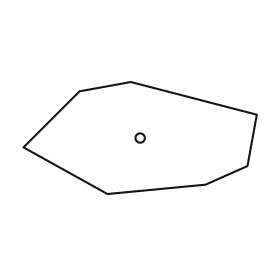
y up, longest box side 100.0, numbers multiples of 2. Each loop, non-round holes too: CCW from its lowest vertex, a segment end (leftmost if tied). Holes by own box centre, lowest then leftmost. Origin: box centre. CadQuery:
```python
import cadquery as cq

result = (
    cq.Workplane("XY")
    .moveTo(-14.0, -24.0)
    .lineTo(28.0, -20.0)
    .lineTo(46.0, -12.0)
    .lineTo(50.0, 10.0)
    .lineTo(-4.0, 24.0)
    .lineTo(-26.0, 20.0)
    .lineTo(-50.0, -4.0)
    .close()
    .moveTo(0.0, 0.0)
    .circle(2.0)
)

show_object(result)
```